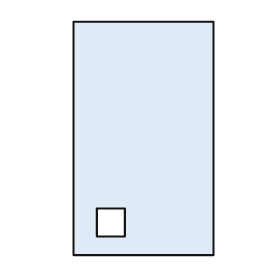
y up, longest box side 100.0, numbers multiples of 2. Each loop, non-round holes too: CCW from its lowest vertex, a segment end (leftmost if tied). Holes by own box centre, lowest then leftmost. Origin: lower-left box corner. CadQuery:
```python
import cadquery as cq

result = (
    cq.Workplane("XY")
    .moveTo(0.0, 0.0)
    .lineTo(60.0, 0.0)
    .lineTo(60.0, 100.0)
    .lineTo(0.0, 100.0)
    .close()
    .moveTo(10.0, 8.0)
    .lineTo(22.0, 8.0)
    .lineTo(22.0, 20.0)
    .lineTo(10.0, 20.0)
    .close()
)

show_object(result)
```